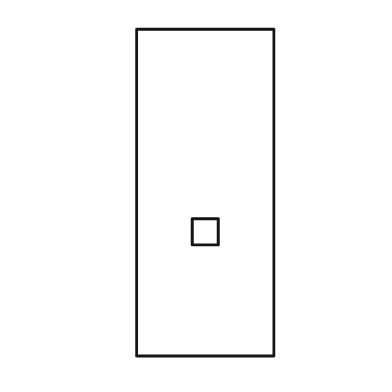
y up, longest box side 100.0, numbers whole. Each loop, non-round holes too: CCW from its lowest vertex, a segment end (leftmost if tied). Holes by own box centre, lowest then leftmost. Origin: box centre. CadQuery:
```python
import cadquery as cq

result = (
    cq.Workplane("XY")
    .moveTo(-21.0, -50.0)
    .lineTo(21.0, -50.0)
    .lineTo(21.0, 50.0)
    .lineTo(-21.0, 50.0)
    .close()
    .moveTo(-4.0, -16.0)
    .lineTo(4.0, -16.0)
    .lineTo(4.0, -8.0)
    .lineTo(-4.0, -8.0)
    .close()
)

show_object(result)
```